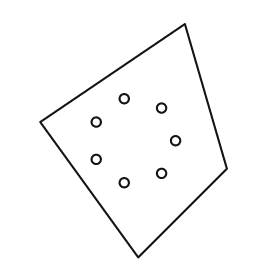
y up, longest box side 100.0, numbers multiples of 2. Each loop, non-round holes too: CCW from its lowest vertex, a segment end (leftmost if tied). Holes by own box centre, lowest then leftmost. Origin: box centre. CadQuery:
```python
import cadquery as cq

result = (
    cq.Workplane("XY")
    .moveTo(2.0, -50.0)
    .lineTo(40.0, -12.0)
    .lineTo(22.0, 50.0)
    .lineTo(-40.0, 8.0)
    .close()
    .moveTo(-4.0, -18.0)
    .circle(2.0)
    .moveTo(12.0, -14.0)
    .circle(2.0)
    .moveTo(-16.0, -8.0)
    .circle(2.0)
    .moveTo(18.0, 0.0)
    .circle(2.0)
    .moveTo(-16.0, 8.0)
    .circle(2.0)
    .moveTo(12.0, 14.0)
    .circle(2.0)
    .moveTo(-4.0, 18.0)
    .circle(2.0)
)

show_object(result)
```